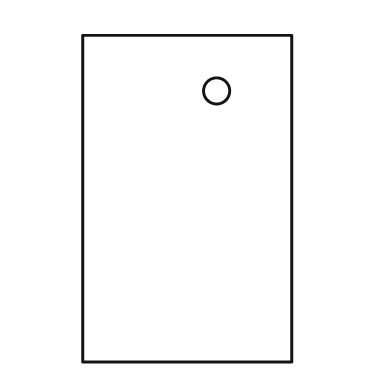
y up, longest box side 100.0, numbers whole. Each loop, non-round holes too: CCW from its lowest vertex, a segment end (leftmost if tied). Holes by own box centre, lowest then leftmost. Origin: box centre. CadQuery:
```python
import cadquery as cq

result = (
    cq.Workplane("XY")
    .moveTo(-32.0, -50.0)
    .lineTo(32.0, -50.0)
    .lineTo(32.0, 50.0)
    .lineTo(-32.0, 50.0)
    .close()
    .moveTo(9.0, 33.0)
    .circle(4.0)
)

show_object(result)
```